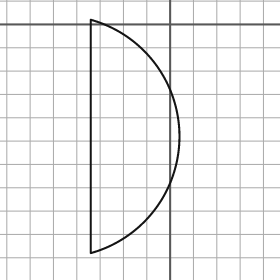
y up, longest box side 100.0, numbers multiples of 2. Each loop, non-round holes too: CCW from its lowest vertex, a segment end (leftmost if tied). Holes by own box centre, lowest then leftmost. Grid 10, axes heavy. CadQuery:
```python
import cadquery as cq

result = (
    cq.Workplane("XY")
    .moveTo(-34.0, -98.0)
    .threePointArc((4.0, -48.0), (-34.0, 2.0))
    .close()
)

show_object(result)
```